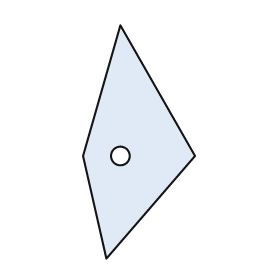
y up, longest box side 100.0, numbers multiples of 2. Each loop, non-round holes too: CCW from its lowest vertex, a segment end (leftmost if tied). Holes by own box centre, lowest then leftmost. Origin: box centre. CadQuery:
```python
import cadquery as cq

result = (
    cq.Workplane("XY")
    .moveTo(-14.0, -50.0)
    .lineTo(24.0, -6.0)
    .lineTo(-8.0, 50.0)
    .lineTo(-24.0, -6.0)
    .close()
    .moveTo(-8.0, -6.0)
    .circle(4.0)
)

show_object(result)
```